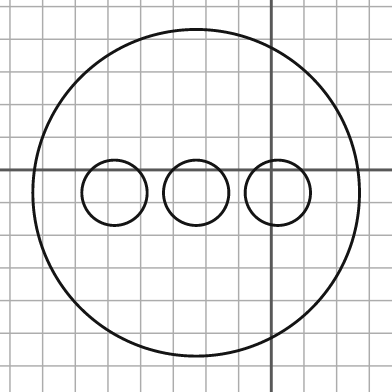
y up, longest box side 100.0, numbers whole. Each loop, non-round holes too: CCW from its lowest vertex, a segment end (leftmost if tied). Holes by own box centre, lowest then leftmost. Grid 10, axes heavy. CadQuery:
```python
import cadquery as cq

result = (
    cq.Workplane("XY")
    .moveTo(-23.0, -7.0)
    .circle(50.0)
    .moveTo(-48.0, -7.0)
    .circle(10.0)
    .moveTo(-23.0, -7.0)
    .circle(10.0)
    .moveTo(2.0, -7.0)
    .circle(10.0)
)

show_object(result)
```